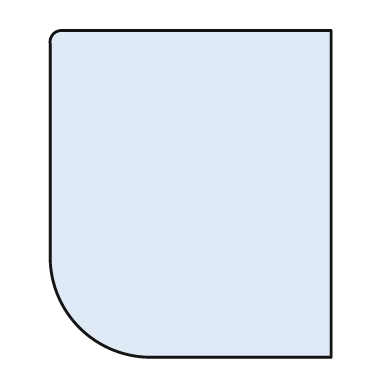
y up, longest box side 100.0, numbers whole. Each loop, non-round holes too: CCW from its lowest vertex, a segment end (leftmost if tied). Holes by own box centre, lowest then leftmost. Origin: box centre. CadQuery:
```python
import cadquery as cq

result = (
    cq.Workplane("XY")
    .moveTo(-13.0, -50.0)
    .lineTo(43.0, -50.0)
    .lineTo(43.0, 50.0)
    .lineTo(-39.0, 50.0)
    .threePointArc((-42.0, 49.0), (-43.0, 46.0))
    .lineTo(-43.0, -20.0)
    .threePointArc((-34.0, -41.0), (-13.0, -50.0))
    .close()
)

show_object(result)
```